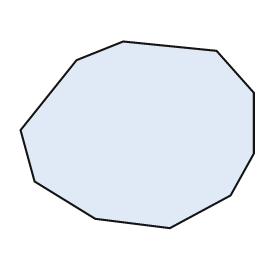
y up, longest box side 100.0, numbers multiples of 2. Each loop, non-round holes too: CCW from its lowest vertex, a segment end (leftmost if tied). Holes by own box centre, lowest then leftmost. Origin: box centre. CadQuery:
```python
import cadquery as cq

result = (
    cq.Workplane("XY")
    .moveTo(14.0, -40.0)
    .lineTo(40.0, -26.0)
    .lineTo(50.0, -8.0)
    .lineTo(50.0, 18.0)
    .lineTo(34.0, 36.0)
    .lineTo(-6.0, 40.0)
    .lineTo(-26.0, 32.0)
    .lineTo(-50.0, 2.0)
    .lineTo(-44.0, -20.0)
    .lineTo(-18.0, -36.0)
    .close()
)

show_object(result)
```